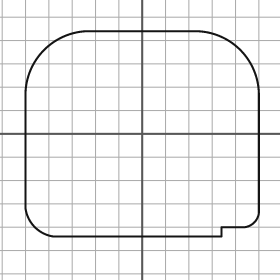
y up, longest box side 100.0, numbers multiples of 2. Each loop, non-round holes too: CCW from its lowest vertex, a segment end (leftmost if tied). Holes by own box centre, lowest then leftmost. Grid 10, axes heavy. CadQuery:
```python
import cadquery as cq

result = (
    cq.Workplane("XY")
    .moveTo(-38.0, -44.0)
    .lineTo(34.0, -44.0)
    .lineTo(34.0, -40.0)
    .lineTo(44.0, -40.0)
    .threePointArc((48.0, -38.0), (50.0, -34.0))
    .lineTo(50.0, 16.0)
    .threePointArc((42.0, 36.0), (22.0, 44.0))
    .lineTo(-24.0, 44.0)
    .threePointArc((-42.0, 36.0), (-50.0, 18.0))
    .lineTo(-50.0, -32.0)
    .threePointArc((-46.0, -40.0), (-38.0, -44.0))
    .close()
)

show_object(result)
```